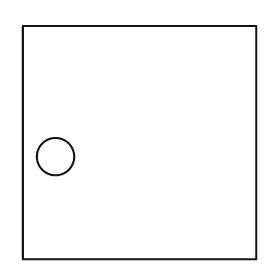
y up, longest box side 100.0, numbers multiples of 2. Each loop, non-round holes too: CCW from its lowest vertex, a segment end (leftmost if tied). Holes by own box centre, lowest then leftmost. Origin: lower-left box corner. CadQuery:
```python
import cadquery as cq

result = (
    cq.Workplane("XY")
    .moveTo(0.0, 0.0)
    .lineTo(100.0, 0.0)
    .lineTo(100.0, 100.0)
    .lineTo(0.0, 100.0)
    .close()
    .moveTo(14.0, 44.0)
    .circle(8.0)
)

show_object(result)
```